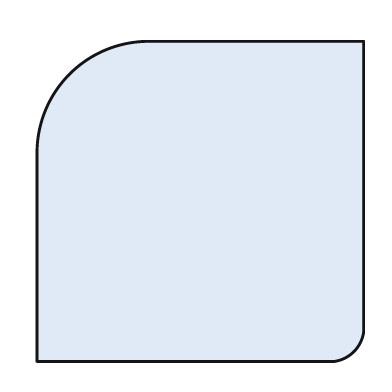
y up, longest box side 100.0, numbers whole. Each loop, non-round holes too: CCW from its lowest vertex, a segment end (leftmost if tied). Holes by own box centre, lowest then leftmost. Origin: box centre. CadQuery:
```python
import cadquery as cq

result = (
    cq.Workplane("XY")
    .moveTo(-50.0, -49.0)
    .lineTo(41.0, -49.0)
    .threePointArc((47.0, -46.0), (50.0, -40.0))
    .lineTo(50.0, 49.0)
    .lineTo(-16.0, 49.0)
    .threePointArc((-40.0, 39.0), (-50.0, 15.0))
    .close()
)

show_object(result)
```